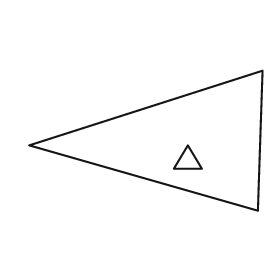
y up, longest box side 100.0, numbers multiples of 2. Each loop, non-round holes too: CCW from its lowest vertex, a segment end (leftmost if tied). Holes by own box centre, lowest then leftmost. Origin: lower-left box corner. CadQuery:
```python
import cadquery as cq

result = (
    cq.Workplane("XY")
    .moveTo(98.0, 0.0)
    .lineTo(100.0, 60.0)
    .lineTo(0.0, 28.0)
    .close()
    .moveTo(62.0, 18.0)
    .lineTo(74.0, 18.0)
    .lineTo(68.0, 28.0)
    .close()
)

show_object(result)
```